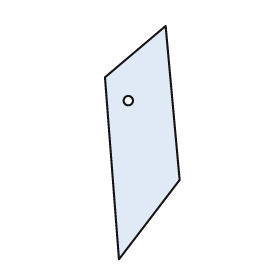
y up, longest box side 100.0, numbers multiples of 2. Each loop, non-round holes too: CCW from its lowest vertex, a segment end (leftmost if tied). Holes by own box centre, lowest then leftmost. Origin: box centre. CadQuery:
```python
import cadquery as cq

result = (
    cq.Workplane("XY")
    .moveTo(-10.0, -50.0)
    .lineTo(16.0, -16.0)
    .lineTo(10.0, 50.0)
    .lineTo(-16.0, 28.0)
    .close()
    .moveTo(-6.0, 18.0)
    .circle(2.0)
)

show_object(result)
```